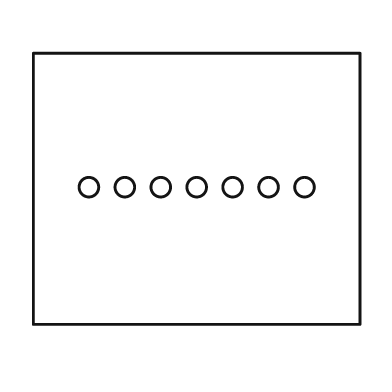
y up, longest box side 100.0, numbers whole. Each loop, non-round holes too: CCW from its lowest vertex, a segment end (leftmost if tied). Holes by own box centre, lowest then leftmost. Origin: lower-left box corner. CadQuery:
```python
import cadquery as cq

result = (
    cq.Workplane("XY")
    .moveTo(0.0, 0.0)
    .lineTo(100.0, 0.0)
    .lineTo(100.0, 83.0)
    .lineTo(0.0, 83.0)
    .close()
    .moveTo(17.0, 42.0)
    .circle(3.0)
    .moveTo(28.0, 42.0)
    .circle(3.0)
    .moveTo(39.0, 42.0)
    .circle(3.0)
    .moveTo(50.0, 42.0)
    .circle(3.0)
    .moveTo(61.0, 42.0)
    .circle(3.0)
    .moveTo(72.0, 42.0)
    .circle(3.0)
    .moveTo(83.0, 42.0)
    .circle(3.0)
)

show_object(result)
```